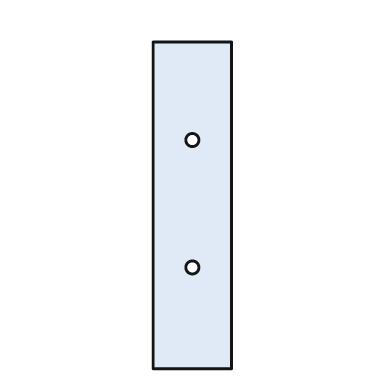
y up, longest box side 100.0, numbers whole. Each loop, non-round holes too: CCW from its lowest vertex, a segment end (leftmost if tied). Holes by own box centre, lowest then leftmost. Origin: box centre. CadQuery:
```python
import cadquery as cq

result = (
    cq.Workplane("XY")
    .moveTo(-12.0, -50.0)
    .lineTo(12.0, -50.0)
    .lineTo(12.0, 50.0)
    .lineTo(-12.0, 50.0)
    .close()
    .moveTo(0.0, -19.0)
    .circle(2.0)
    .moveTo(0.0, 20.0)
    .circle(2.0)
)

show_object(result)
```